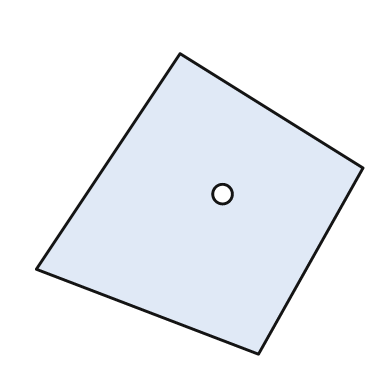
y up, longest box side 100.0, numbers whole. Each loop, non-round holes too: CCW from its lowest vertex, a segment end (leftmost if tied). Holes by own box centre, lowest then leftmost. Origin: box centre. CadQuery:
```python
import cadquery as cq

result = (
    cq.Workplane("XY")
    .moveTo(18.0, -46.0)
    .lineTo(50.0, 11.0)
    .lineTo(-6.0, 46.0)
    .lineTo(-50.0, -20.0)
    .close()
    .moveTo(7.0, 3.0)
    .circle(3.0)
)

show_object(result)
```